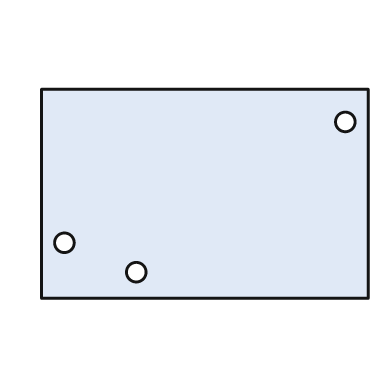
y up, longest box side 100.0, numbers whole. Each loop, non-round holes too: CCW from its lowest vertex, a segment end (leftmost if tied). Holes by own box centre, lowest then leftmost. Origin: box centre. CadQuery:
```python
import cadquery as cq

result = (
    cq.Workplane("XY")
    .moveTo(-50.0, -32.0)
    .lineTo(50.0, -32.0)
    .lineTo(50.0, 32.0)
    .lineTo(-50.0, 32.0)
    .close()
    .moveTo(-21.0, -24.0)
    .circle(3.0)
    .moveTo(-43.0, -15.0)
    .circle(3.0)
    .moveTo(43.0, 22.0)
    .circle(3.0)
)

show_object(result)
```